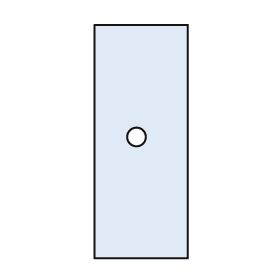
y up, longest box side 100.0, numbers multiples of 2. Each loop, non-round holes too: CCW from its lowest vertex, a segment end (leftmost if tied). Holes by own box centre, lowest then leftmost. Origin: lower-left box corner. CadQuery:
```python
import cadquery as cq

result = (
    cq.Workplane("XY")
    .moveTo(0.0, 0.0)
    .lineTo(40.0, 0.0)
    .lineTo(40.0, 100.0)
    .lineTo(0.0, 100.0)
    .close()
    .moveTo(18.0, 52.0)
    .circle(4.0)
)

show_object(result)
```